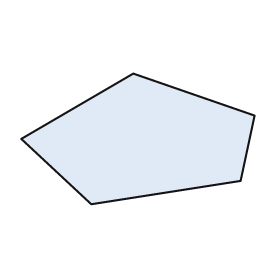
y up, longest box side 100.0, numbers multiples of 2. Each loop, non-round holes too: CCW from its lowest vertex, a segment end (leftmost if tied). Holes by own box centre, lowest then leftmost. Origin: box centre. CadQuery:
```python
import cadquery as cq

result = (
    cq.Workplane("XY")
    .moveTo(-20.0, -28.0)
    .lineTo(44.0, -18.0)
    .lineTo(50.0, 10.0)
    .lineTo(-2.0, 28.0)
    .lineTo(-50.0, 0.0)
    .close()
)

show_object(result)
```